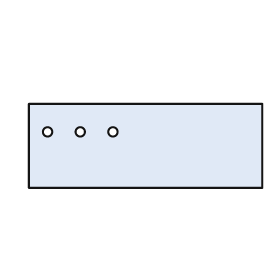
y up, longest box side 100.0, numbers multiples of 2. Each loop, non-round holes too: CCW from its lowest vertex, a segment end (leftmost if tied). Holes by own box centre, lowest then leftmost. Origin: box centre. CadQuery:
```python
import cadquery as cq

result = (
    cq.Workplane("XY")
    .moveTo(-50.0, -18.0)
    .lineTo(50.0, -18.0)
    .lineTo(50.0, 18.0)
    .lineTo(-50.0, 18.0)
    .close()
    .moveTo(-42.0, 6.0)
    .circle(2.0)
    .moveTo(-28.0, 6.0)
    .circle(2.0)
    .moveTo(-14.0, 6.0)
    .circle(2.0)
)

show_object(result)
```